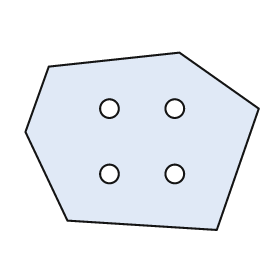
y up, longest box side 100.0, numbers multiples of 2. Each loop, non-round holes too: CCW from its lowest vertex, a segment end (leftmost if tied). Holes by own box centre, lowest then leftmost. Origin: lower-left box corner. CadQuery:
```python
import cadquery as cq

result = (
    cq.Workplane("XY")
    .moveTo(82.0, 0.0)
    .lineTo(100.0, 52.0)
    .lineTo(66.0, 76.0)
    .lineTo(10.0, 70.0)
    .lineTo(0.0, 42.0)
    .lineTo(18.0, 4.0)
    .close()
    .moveTo(36.0, 24.0)
    .circle(4.0)
    .moveTo(64.0, 24.0)
    .circle(4.0)
    .moveTo(36.0, 52.0)
    .circle(4.0)
    .moveTo(64.0, 52.0)
    .circle(4.0)
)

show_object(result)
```